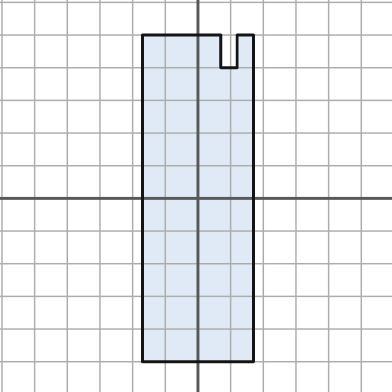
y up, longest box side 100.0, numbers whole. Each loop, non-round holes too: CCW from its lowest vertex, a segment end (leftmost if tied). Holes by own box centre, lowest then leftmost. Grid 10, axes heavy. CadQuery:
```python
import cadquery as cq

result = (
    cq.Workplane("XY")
    .moveTo(-17.0, -50.0)
    .lineTo(17.0, -50.0)
    .lineTo(17.0, 50.0)
    .lineTo(12.0, 50.0)
    .lineTo(12.0, 40.0)
    .lineTo(7.0, 40.0)
    .lineTo(7.0, 50.0)
    .lineTo(-17.0, 50.0)
    .close()
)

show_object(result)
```